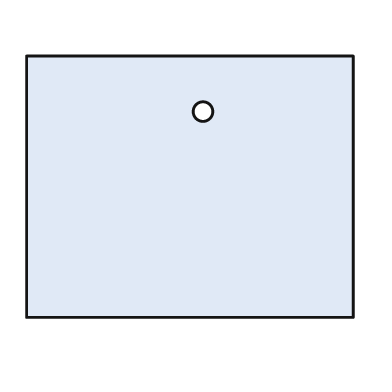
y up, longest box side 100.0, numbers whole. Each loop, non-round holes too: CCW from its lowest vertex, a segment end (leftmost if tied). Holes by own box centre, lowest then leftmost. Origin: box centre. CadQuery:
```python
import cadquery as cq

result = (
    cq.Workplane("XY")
    .moveTo(-50.0, -40.0)
    .lineTo(50.0, -40.0)
    .lineTo(50.0, 40.0)
    .lineTo(-50.0, 40.0)
    .close()
    .moveTo(4.0, 23.0)
    .circle(3.0)
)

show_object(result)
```